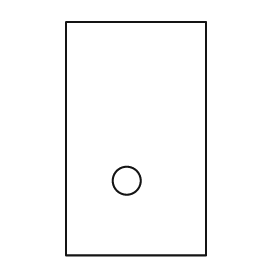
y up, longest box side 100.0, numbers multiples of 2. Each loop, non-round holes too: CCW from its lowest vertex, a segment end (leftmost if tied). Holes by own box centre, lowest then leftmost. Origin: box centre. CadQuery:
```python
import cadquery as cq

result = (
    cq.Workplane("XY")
    .moveTo(-30.0, -50.0)
    .lineTo(30.0, -50.0)
    .lineTo(30.0, 50.0)
    .lineTo(-30.0, 50.0)
    .close()
    .moveTo(-4.0, -18.0)
    .circle(6.0)
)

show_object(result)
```